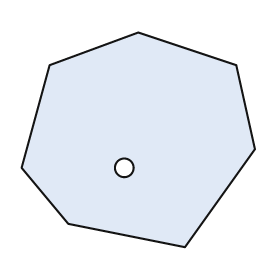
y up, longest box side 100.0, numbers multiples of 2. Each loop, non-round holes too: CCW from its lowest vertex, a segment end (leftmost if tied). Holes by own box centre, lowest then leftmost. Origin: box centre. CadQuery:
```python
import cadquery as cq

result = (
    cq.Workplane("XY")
    .moveTo(20.0, -46.0)
    .lineTo(50.0, -4.0)
    .lineTo(42.0, 32.0)
    .lineTo(0.0, 46.0)
    .lineTo(-38.0, 32.0)
    .lineTo(-50.0, -12.0)
    .lineTo(-30.0, -36.0)
    .close()
    .moveTo(-6.0, -12.0)
    .circle(4.0)
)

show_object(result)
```